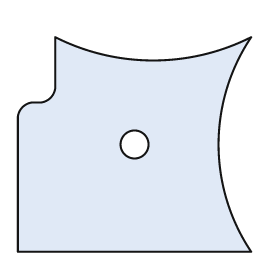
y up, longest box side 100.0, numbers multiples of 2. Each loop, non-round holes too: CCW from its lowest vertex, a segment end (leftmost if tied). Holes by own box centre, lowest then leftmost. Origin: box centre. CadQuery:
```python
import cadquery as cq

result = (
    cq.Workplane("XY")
    .moveTo(-50.0, -46.0)
    .lineTo(50.0, -46.0)
    .threePointArc((36.0, 0.0), (50.0, 46.0))
    .threePointArc((8.0, 36.0), (-34.0, 46.0))
    .lineTo(-34.0, 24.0)
    .threePointArc((-36.0, 20.0), (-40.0, 18.0))
    .lineTo(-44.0, 18.0)
    .threePointArc((-48.0, 16.0), (-50.0, 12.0))
    .close()
    .moveTo(0.0, 0.0)
    .circle(6.0)
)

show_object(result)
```